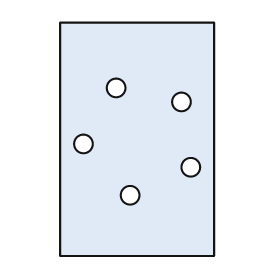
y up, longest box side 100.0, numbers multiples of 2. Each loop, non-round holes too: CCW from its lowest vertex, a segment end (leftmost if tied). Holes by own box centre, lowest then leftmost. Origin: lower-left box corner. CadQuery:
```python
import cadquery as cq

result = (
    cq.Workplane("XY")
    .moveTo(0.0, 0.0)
    .lineTo(66.0, 0.0)
    .lineTo(66.0, 100.0)
    .lineTo(0.0, 100.0)
    .close()
    .moveTo(30.0, 26.0)
    .circle(4.0)
    .moveTo(56.0, 38.0)
    .circle(4.0)
    .moveTo(10.0, 48.0)
    .circle(4.0)
    .moveTo(52.0, 66.0)
    .circle(4.0)
    .moveTo(24.0, 72.0)
    .circle(4.0)
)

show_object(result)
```